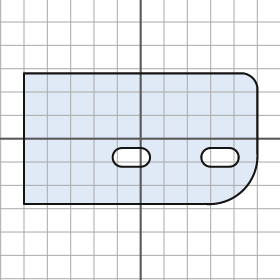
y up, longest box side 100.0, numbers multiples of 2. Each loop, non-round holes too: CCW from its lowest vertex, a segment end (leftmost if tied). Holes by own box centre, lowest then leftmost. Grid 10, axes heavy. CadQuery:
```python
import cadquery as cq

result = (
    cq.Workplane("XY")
    .moveTo(-50.0, -28.0)
    .lineTo(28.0, -28.0)
    .threePointArc((44.0, -22.0), (50.0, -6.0))
    .lineTo(50.0, 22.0)
    .threePointArc((48.0, 26.0), (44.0, 28.0))
    .lineTo(-50.0, 28.0)
    .close()
    .moveTo(-8.0, -12.0)
    .lineTo(0.0, -12.0)
    .threePointArc((4.0, -8.0), (0.0, -4.0))
    .lineTo(-8.0, -4.0)
    .threePointArc((-12.0, -8.0), (-8.0, -12.0))
    .close()
    .moveTo(30.0, -12.0)
    .lineTo(38.0, -12.0)
    .threePointArc((42.0, -8.0), (38.0, -4.0))
    .lineTo(30.0, -4.0)
    .threePointArc((26.0, -8.0), (30.0, -12.0))
    .close()
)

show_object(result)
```